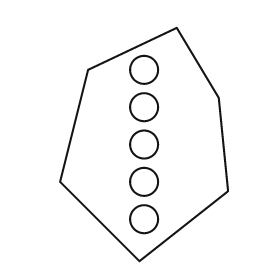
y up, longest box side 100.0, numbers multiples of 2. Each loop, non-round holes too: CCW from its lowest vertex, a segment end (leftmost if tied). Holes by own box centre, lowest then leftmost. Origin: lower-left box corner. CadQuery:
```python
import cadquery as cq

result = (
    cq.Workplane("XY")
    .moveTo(34.0, 0.0)
    .lineTo(72.0, 30.0)
    .lineTo(68.0, 70.0)
    .lineTo(50.0, 100.0)
    .lineTo(12.0, 82.0)
    .lineTo(0.0, 34.0)
    .close()
    .moveTo(36.0, 18.0)
    .circle(6.0)
    .moveTo(36.0, 34.0)
    .circle(6.0)
    .moveTo(36.0, 50.0)
    .circle(6.0)
    .moveTo(36.0, 66.0)
    .circle(6.0)
    .moveTo(36.0, 82.0)
    .circle(6.0)
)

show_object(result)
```